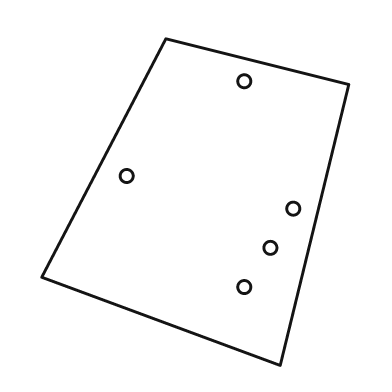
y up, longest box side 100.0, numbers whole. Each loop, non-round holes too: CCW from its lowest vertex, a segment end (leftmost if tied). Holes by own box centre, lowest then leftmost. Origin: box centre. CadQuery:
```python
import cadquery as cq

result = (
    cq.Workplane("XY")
    .moveTo(26.0, -50.0)
    .lineTo(47.0, 36.0)
    .lineTo(-9.0, 50.0)
    .lineTo(-47.0, -23.0)
    .close()
    .moveTo(15.0, -26.0)
    .circle(2.0)
    .moveTo(23.0, -14.0)
    .circle(2.0)
    .moveTo(30.0, -2.0)
    .circle(2.0)
    .moveTo(-21.0, 8.0)
    .circle(2.0)
    .moveTo(15.0, 37.0)
    .circle(2.0)
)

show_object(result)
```